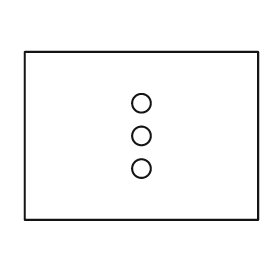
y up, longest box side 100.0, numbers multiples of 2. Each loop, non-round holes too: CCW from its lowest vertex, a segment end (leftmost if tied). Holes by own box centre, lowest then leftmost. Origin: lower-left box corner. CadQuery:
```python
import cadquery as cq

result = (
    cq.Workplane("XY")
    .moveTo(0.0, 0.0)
    .lineTo(100.0, 0.0)
    .lineTo(100.0, 72.0)
    .lineTo(0.0, 72.0)
    .close()
    .moveTo(50.0, 22.0)
    .circle(4.0)
    .moveTo(50.0, 36.0)
    .circle(4.0)
    .moveTo(50.0, 50.0)
    .circle(4.0)
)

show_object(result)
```